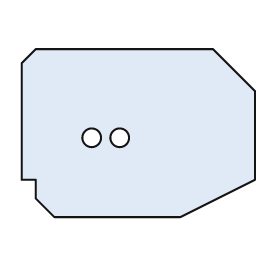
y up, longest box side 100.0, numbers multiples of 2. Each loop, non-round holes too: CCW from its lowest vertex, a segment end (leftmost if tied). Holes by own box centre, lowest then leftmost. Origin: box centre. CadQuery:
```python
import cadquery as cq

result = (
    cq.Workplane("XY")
    .moveTo(-36.0, -36.0)
    .lineTo(18.0, -36.0)
    .lineTo(50.0, -20.0)
    .lineTo(50.0, 18.0)
    .lineTo(32.0, 36.0)
    .lineTo(-44.0, 36.0)
    .lineTo(-50.0, 30.0)
    .lineTo(-50.0, -20.0)
    .lineTo(-44.0, -20.0)
    .lineTo(-44.0, -28.0)
    .close()
    .moveTo(-20.0, -2.0)
    .circle(4.0)
    .moveTo(-8.0, -2.0)
    .circle(4.0)
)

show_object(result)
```